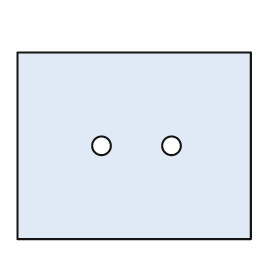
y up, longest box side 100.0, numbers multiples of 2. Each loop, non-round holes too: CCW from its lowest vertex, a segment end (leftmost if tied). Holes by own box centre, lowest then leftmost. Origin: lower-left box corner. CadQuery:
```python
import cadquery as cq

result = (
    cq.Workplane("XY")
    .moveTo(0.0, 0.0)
    .lineTo(100.0, 0.0)
    .lineTo(100.0, 80.0)
    .lineTo(0.0, 80.0)
    .close()
    .moveTo(36.0, 40.0)
    .circle(4.0)
    .moveTo(66.0, 40.0)
    .circle(4.0)
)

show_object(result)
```